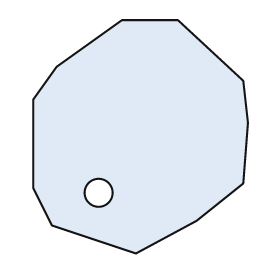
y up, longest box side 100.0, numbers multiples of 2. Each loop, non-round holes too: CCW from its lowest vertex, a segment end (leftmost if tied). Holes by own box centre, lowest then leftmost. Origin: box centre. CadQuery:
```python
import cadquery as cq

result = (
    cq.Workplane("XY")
    .moveTo(-2.0, -50.0)
    .lineTo(24.0, -36.0)
    .lineTo(44.0, -20.0)
    .lineTo(46.0, 6.0)
    .lineTo(44.0, 24.0)
    .lineTo(16.0, 50.0)
    .lineTo(-8.0, 50.0)
    .lineTo(-36.0, 30.0)
    .lineTo(-46.0, 16.0)
    .lineTo(-46.0, -22.0)
    .lineTo(-38.0, -38.0)
    .close()
    .moveTo(-18.0, -24.0)
    .circle(6.0)
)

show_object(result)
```